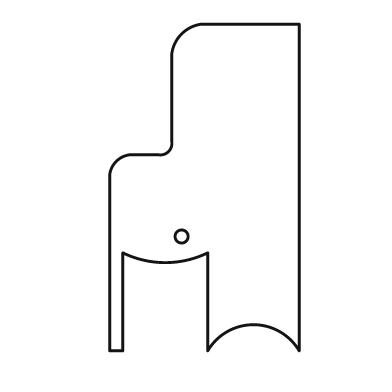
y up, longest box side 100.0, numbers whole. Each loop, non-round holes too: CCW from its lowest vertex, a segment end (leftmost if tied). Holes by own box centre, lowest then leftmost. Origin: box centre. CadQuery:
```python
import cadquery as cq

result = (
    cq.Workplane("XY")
    .moveTo(-29.0, -50.0)
    .lineTo(-25.0, -50.0)
    .lineTo(-25.0, -20.0)
    .threePointArc((-12.0, -23.0), (1.0, -20.0))
    .lineTo(1.0, -50.0)
    .threePointArc((15.0, -42.0), (29.0, -50.0))
    .lineTo(29.0, 50.0)
    .lineTo(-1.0, 50.0)
    .threePointArc((-7.0, 47.0), (-10.0, 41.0))
    .lineTo(-10.0, 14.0)
    .threePointArc((-11.0, 11.0), (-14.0, 10.0))
    .lineTo(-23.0, 10.0)
    .threePointArc((-27.0, 8.0), (-29.0, 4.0))
    .close()
    .moveTo(-7.0, -15.0)
    .circle(2.0)
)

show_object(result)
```